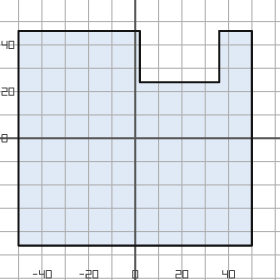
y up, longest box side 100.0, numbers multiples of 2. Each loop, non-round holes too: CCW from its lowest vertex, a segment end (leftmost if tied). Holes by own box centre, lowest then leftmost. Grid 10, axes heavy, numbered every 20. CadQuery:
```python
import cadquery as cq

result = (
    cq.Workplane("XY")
    .moveTo(-50.0, -46.0)
    .lineTo(50.0, -46.0)
    .lineTo(50.0, 46.0)
    .lineTo(36.0, 46.0)
    .lineTo(36.0, 24.0)
    .lineTo(2.0, 24.0)
    .lineTo(2.0, 46.0)
    .lineTo(-50.0, 46.0)
    .close()
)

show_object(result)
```